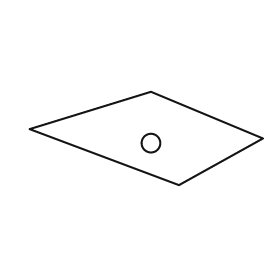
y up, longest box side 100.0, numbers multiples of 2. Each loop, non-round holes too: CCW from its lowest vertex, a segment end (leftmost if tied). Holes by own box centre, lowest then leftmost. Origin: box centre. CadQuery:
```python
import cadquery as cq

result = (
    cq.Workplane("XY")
    .moveTo(14.0, -20.0)
    .lineTo(50.0, 0.0)
    .lineTo(2.0, 20.0)
    .lineTo(-50.0, 4.0)
    .close()
    .moveTo(2.0, -2.0)
    .circle(4.0)
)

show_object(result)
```